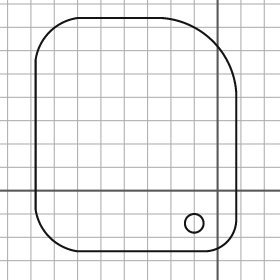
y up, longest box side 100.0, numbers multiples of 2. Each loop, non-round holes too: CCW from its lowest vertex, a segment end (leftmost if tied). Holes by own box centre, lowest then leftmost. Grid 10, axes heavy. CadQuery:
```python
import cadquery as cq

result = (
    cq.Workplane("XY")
    .moveTo(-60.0, -26.0)
    .lineTo(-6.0, -26.0)
    .threePointArc((4.0, -22.0), (8.0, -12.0))
    .lineTo(8.0, 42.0)
    .threePointArc((-2.0, 64.0), (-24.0, 74.0))
    .lineTo(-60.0, 74.0)
    .threePointArc((-72.0, 68.0), (-78.0, 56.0))
    .lineTo(-78.0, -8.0)
    .threePointArc((-72.0, -20.0), (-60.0, -26.0))
    .close()
    .moveTo(-10.0, -14.0)
    .circle(4.0)
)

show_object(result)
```